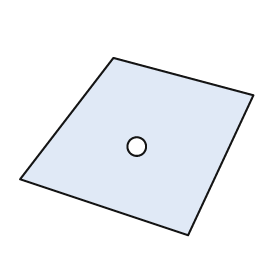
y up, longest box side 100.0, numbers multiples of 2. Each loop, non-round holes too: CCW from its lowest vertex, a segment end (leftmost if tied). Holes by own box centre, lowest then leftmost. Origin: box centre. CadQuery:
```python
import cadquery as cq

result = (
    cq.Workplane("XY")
    .moveTo(22.0, -38.0)
    .lineTo(50.0, 22.0)
    .lineTo(-10.0, 38.0)
    .lineTo(-50.0, -14.0)
    .close()
    .moveTo(0.0, 0.0)
    .circle(4.0)
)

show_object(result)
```